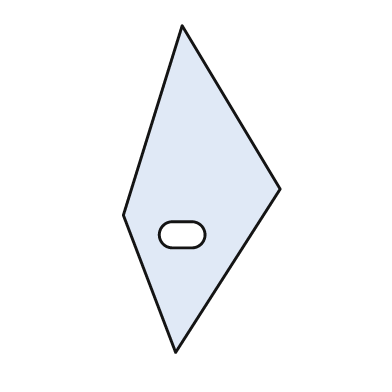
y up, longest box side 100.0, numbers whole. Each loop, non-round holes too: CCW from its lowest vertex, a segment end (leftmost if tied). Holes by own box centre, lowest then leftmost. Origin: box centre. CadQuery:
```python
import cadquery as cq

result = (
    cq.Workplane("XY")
    .moveTo(-8.0, -50.0)
    .lineTo(24.0, 0.0)
    .lineTo(-6.0, 50.0)
    .lineTo(-24.0, -8.0)
    .close()
    .moveTo(-9.0, -18.0)
    .lineTo(-3.0, -18.0)
    .threePointArc((1.0, -14.0), (-3.0, -10.0))
    .lineTo(-9.0, -10.0)
    .threePointArc((-13.0, -14.0), (-9.0, -18.0))
    .close()
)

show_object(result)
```